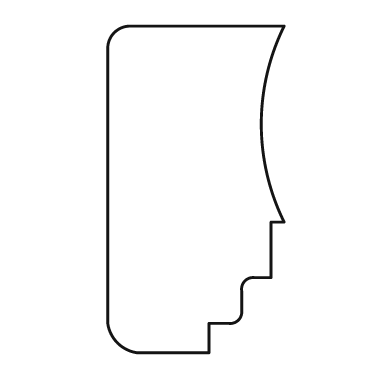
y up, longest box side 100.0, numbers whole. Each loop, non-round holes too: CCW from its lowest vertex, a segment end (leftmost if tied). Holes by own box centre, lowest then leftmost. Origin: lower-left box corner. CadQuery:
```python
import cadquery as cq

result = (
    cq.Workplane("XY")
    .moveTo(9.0, 0.0)
    .lineTo(31.0, 0.0)
    .lineTo(31.0, 9.0)
    .lineTo(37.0, 9.0)
    .threePointArc((40.0, 10.0), (41.0, 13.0))
    .lineTo(41.0, 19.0)
    .threePointArc((42.0, 22.0), (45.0, 23.0))
    .lineTo(50.0, 23.0)
    .lineTo(50.0, 40.0)
    .lineTo(54.0, 40.0)
    .threePointArc((47.0, 70.0), (54.0, 100.0))
    .lineTo(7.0, 100.0)
    .threePointArc((2.0, 98.0), (0.0, 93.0))
    .lineTo(0.0, 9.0)
    .threePointArc((3.0, 3.0), (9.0, 0.0))
    .close()
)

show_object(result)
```